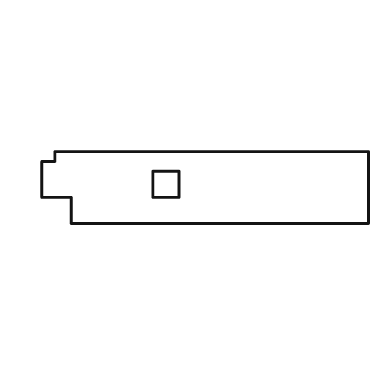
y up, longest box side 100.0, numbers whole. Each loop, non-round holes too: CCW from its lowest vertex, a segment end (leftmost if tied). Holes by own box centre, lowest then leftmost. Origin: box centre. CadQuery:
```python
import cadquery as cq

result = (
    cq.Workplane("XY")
    .moveTo(-41.0, -11.0)
    .lineTo(50.0, -11.0)
    .lineTo(50.0, 11.0)
    .lineTo(-46.0, 11.0)
    .lineTo(-46.0, 8.0)
    .lineTo(-50.0, 8.0)
    .lineTo(-50.0, -3.0)
    .lineTo(-41.0, -3.0)
    .close()
    .moveTo(-16.0, -3.0)
    .lineTo(-8.0, -3.0)
    .lineTo(-8.0, 5.0)
    .lineTo(-16.0, 5.0)
    .close()
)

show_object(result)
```